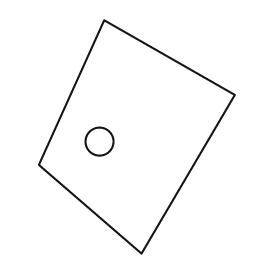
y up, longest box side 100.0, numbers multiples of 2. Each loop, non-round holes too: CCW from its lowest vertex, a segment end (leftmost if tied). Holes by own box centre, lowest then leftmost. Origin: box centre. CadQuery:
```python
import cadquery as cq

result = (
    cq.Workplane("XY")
    .moveTo(2.0, -50.0)
    .lineTo(42.0, 18.0)
    .lineTo(-14.0, 50.0)
    .lineTo(-42.0, -12.0)
    .close()
    .moveTo(-16.0, -2.0)
    .circle(6.0)
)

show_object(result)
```